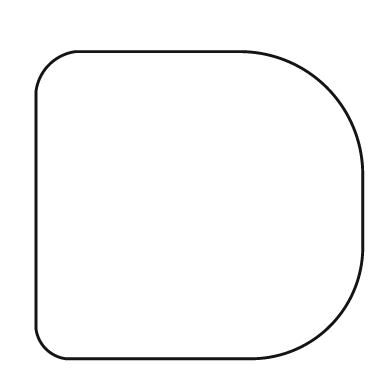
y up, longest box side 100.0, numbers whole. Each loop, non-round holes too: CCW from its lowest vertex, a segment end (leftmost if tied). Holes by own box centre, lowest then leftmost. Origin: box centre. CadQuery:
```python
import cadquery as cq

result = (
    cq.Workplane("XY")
    .moveTo(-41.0, -47.0)
    .lineTo(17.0, -47.0)
    .threePointArc((40.0, -37.0), (50.0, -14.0))
    .lineTo(50.0, 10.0)
    .threePointArc((39.0, 36.0), (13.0, 47.0))
    .lineTo(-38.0, 47.0)
    .threePointArc((-46.0, 43.0), (-50.0, 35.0))
    .lineTo(-50.0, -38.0)
    .threePointArc((-47.0, -44.0), (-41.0, -47.0))
    .close()
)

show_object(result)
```